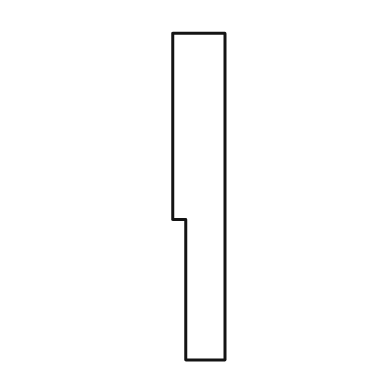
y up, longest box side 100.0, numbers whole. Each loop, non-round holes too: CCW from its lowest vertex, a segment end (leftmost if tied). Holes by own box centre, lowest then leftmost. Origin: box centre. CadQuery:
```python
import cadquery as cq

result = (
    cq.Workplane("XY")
    .moveTo(-4.0, -50.0)
    .lineTo(8.0, -50.0)
    .lineTo(8.0, 50.0)
    .lineTo(-8.0, 50.0)
    .lineTo(-8.0, -7.0)
    .lineTo(-4.0, -7.0)
    .close()
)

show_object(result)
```